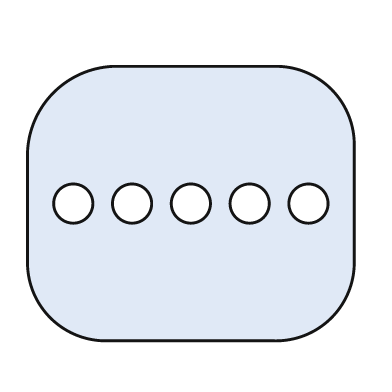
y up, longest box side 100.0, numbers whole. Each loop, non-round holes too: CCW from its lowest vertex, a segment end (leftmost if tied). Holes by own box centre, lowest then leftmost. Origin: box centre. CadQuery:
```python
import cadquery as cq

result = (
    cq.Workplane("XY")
    .moveTo(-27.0, -42.0)
    .lineTo(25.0, -42.0)
    .threePointArc((43.0, -35.0), (50.0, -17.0))
    .lineTo(50.0, 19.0)
    .threePointArc((43.0, 35.0), (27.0, 42.0))
    .lineTo(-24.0, 42.0)
    .threePointArc((-42.0, 34.0), (-50.0, 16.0))
    .lineTo(-50.0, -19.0)
    .threePointArc((-43.0, -35.0), (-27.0, -42.0))
    .close()
    .moveTo(-36.0, 0.0)
    .circle(6.0)
    .moveTo(-18.0, 0.0)
    .circle(6.0)
    .moveTo(0.0, 0.0)
    .circle(6.0)
    .moveTo(18.0, 0.0)
    .circle(6.0)
    .moveTo(36.0, 0.0)
    .circle(6.0)
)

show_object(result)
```